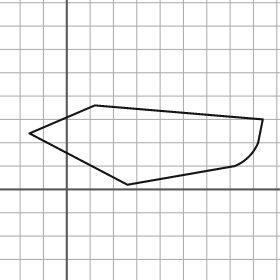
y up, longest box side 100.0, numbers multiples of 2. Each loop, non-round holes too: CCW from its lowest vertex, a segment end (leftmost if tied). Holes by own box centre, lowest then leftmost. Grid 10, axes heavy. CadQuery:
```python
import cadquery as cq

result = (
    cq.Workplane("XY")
    .moveTo(26.0, 2.0)
    .lineTo(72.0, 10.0)
    .threePointArc((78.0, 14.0), (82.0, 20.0))
    .lineTo(84.0, 30.0)
    .lineTo(12.0, 36.0)
    .lineTo(-16.0, 24.0)
    .close()
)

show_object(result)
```